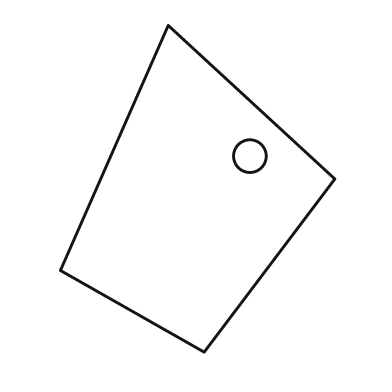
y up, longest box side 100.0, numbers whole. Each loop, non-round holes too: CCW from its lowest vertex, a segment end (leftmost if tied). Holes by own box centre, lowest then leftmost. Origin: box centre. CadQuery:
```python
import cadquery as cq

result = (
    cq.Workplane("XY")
    .moveTo(2.0, -50.0)
    .lineTo(42.0, 3.0)
    .lineTo(-9.0, 50.0)
    .lineTo(-42.0, -25.0)
    .close()
    .moveTo(16.0, 10.0)
    .circle(5.0)
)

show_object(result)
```